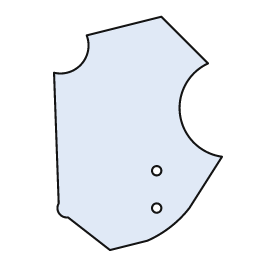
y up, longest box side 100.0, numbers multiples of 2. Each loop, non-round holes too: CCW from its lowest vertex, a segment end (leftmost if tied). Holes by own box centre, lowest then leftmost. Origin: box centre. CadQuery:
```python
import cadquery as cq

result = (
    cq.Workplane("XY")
    .moveTo(-12.0, -50.0)
    .lineTo(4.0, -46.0)
    .threePointArc((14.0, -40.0), (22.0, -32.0))
    .lineTo(36.0, -10.0)
    .threePointArc((18.0, 8.0), (30.0, 30.0))
    .lineTo(10.0, 50.0)
    .lineTo(-22.0, 42.0)
    .threePointArc((-24.0, 30.0), (-36.0, 26.0))
    .lineTo(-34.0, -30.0)
    .threePointArc((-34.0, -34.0), (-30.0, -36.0))
    .close()
    .moveTo(8.0, -32.0)
    .circle(2.0)
    .moveTo(8.0, -16.0)
    .circle(2.0)
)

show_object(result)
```